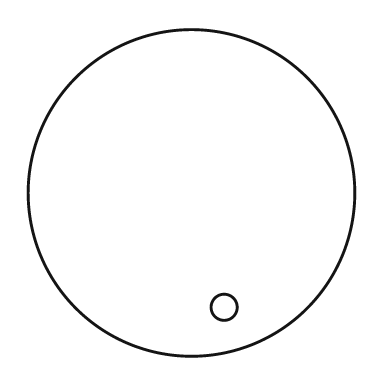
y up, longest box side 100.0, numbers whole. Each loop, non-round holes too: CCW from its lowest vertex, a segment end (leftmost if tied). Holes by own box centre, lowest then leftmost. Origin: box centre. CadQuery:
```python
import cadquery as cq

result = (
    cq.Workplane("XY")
    .moveTo(0.0, 0.0)
    .circle(50.0)
    .moveTo(10.0, -35.0)
    .circle(4.0)
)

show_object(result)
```